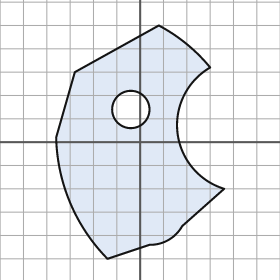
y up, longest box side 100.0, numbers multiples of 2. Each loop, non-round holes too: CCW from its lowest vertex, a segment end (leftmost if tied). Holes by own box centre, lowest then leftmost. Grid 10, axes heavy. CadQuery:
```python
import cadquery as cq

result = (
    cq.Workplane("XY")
    .moveTo(-14.0, -50.0)
    .lineTo(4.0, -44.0)
    .threePointArc((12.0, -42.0), (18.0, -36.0))
    .lineTo(36.0, -20.0)
    .threePointArc((16.0, 4.0), (30.0, 32.0))
    .threePointArc((20.0, 42.0), (8.0, 50.0))
    .lineTo(-28.0, 30.0)
    .lineTo(-36.0, 2.0)
    .threePointArc((-30.0, -26.0), (-14.0, -50.0))
    .close()
    .moveTo(-4.0, 14.0)
    .circle(8.0)
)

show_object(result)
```